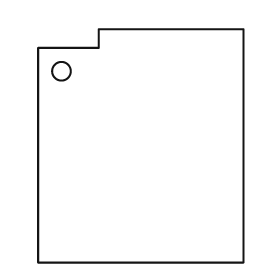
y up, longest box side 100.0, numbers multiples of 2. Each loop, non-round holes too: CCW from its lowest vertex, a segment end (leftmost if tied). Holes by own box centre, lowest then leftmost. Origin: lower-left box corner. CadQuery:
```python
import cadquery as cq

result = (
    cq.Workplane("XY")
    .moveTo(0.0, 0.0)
    .lineTo(88.0, 0.0)
    .lineTo(88.0, 100.0)
    .lineTo(26.0, 100.0)
    .lineTo(26.0, 92.0)
    .lineTo(0.0, 92.0)
    .close()
    .moveTo(10.0, 82.0)
    .circle(4.0)
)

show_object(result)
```